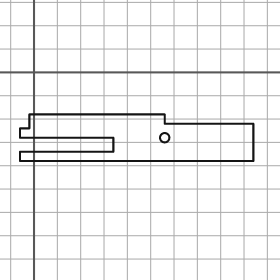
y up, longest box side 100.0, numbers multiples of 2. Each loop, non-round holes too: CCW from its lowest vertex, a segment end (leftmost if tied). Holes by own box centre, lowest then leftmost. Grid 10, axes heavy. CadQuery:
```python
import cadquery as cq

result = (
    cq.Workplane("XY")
    .moveTo(-6.0, -38.0)
    .lineTo(94.0, -38.0)
    .lineTo(94.0, -22.0)
    .lineTo(56.0, -22.0)
    .lineTo(56.0, -18.0)
    .lineTo(-2.0, -18.0)
    .lineTo(-2.0, -24.0)
    .lineTo(-6.0, -24.0)
    .lineTo(-6.0, -28.0)
    .lineTo(34.0, -28.0)
    .lineTo(34.0, -34.0)
    .lineTo(-6.0, -34.0)
    .close()
    .moveTo(56.0, -28.0)
    .circle(2.0)
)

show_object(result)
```